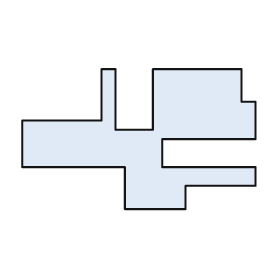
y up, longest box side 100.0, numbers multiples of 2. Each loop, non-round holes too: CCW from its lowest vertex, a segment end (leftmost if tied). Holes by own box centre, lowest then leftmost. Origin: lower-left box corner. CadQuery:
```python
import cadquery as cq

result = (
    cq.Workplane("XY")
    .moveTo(44.0, 0.0)
    .lineTo(70.0, 0.0)
    .lineTo(70.0, 10.0)
    .lineTo(100.0, 10.0)
    .lineTo(100.0, 18.0)
    .lineTo(60.0, 18.0)
    .lineTo(60.0, 30.0)
    .lineTo(100.0, 30.0)
    .lineTo(100.0, 46.0)
    .lineTo(94.0, 46.0)
    .lineTo(94.0, 60.0)
    .lineTo(56.0, 60.0)
    .lineTo(56.0, 34.0)
    .lineTo(40.0, 34.0)
    .lineTo(40.0, 60.0)
    .lineTo(34.0, 60.0)
    .lineTo(34.0, 38.0)
    .lineTo(0.0, 38.0)
    .lineTo(0.0, 18.0)
    .lineTo(44.0, 18.0)
    .close()
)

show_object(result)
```